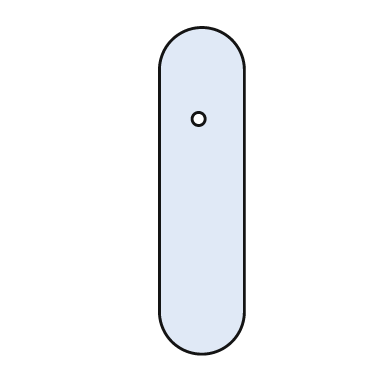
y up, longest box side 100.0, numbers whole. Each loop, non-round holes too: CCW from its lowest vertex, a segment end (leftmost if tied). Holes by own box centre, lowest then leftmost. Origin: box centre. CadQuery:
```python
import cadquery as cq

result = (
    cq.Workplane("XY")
    .moveTo(-13.0, -37.0)
    .threePointArc((0.0, -50.0), (13.0, -37.0))
    .lineTo(13.0, 37.0)
    .threePointArc((0.0, 50.0), (-13.0, 37.0))
    .close()
    .moveTo(-1.0, 22.0)
    .circle(2.0)
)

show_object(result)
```